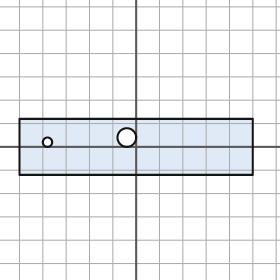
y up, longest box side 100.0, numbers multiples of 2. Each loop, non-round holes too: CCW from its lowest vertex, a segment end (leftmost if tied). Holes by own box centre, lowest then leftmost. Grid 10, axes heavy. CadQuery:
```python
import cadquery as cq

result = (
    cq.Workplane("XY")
    .moveTo(-50.0, -12.0)
    .lineTo(50.0, -12.0)
    .lineTo(50.0, 12.0)
    .lineTo(-50.0, 12.0)
    .close()
    .moveTo(-38.0, 2.0)
    .circle(2.0)
    .moveTo(-4.0, 4.0)
    .circle(4.0)
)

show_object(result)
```